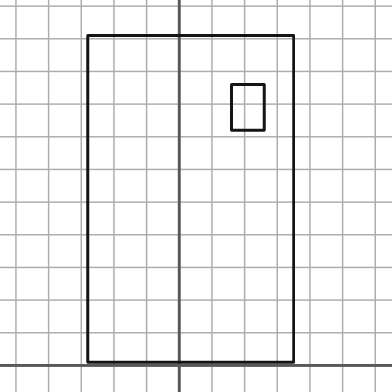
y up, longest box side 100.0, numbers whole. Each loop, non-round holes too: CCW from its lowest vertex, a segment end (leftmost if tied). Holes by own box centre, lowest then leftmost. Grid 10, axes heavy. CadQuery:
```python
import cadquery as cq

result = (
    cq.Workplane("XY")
    .moveTo(-28.0, 1.0)
    .lineTo(35.0, 1.0)
    .lineTo(35.0, 101.0)
    .lineTo(-28.0, 101.0)
    .close()
    .moveTo(16.0, 72.0)
    .lineTo(26.0, 72.0)
    .lineTo(26.0, 86.0)
    .lineTo(16.0, 86.0)
    .close()
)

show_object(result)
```